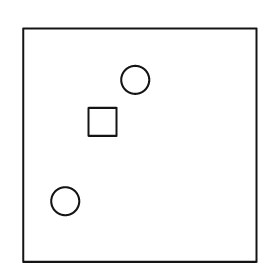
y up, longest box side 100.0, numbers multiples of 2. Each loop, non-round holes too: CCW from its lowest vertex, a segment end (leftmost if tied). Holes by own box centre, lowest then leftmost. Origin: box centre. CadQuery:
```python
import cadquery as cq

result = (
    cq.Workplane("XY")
    .moveTo(-50.0, -50.0)
    .lineTo(50.0, -50.0)
    .lineTo(50.0, 50.0)
    .lineTo(-50.0, 50.0)
    .close()
    .moveTo(-32.0, -24.0)
    .circle(6.0)
    .moveTo(-22.0, 4.0)
    .lineTo(-10.0, 4.0)
    .lineTo(-10.0, 16.0)
    .lineTo(-22.0, 16.0)
    .close()
    .moveTo(-2.0, 28.0)
    .circle(6.0)
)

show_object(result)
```